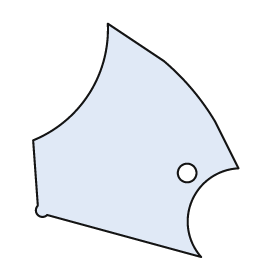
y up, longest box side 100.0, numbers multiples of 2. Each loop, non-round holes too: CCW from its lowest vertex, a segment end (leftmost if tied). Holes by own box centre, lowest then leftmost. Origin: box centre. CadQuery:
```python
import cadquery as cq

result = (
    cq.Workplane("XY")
    .moveTo(28.0, -50.0)
    .threePointArc((24.0, -26.0), (44.0, -12.0))
    .lineTo(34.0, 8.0)
    .threePointArc((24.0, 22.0), (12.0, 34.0))
    .lineTo(-12.0, 50.0)
    .threePointArc((-20.0, 20.0), (-44.0, 0.0))
    .lineTo(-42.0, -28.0)
    .threePointArc((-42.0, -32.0), (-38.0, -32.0))
    .close()
    .moveTo(22.0, -14.0)
    .circle(4.0)
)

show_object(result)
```